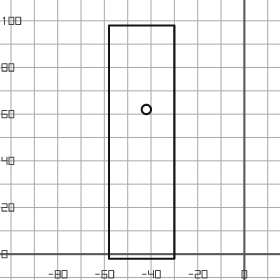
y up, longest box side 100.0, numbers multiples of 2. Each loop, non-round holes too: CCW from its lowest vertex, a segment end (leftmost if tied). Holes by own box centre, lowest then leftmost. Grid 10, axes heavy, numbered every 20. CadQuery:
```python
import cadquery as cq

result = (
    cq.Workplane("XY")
    .moveTo(-58.0, -2.0)
    .lineTo(-30.0, -2.0)
    .lineTo(-30.0, 98.0)
    .lineTo(-58.0, 98.0)
    .close()
    .moveTo(-42.0, 62.0)
    .circle(2.0)
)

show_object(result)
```